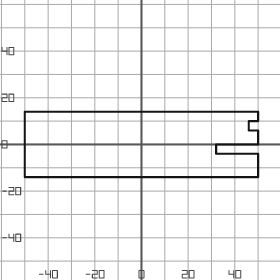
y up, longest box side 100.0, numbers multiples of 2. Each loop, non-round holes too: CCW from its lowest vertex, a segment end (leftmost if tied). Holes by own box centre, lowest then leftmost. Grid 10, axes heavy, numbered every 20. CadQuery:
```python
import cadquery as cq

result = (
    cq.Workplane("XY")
    .moveTo(-50.0, -14.0)
    .lineTo(50.0, -14.0)
    .lineTo(50.0, -4.0)
    .lineTo(32.0, -4.0)
    .lineTo(32.0, 0.0)
    .lineTo(50.0, 0.0)
    .lineTo(50.0, 6.0)
    .lineTo(46.0, 6.0)
    .lineTo(46.0, 10.0)
    .lineTo(50.0, 10.0)
    .lineTo(50.0, 14.0)
    .lineTo(-50.0, 14.0)
    .close()
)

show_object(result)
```